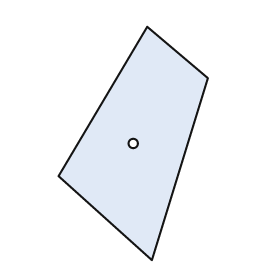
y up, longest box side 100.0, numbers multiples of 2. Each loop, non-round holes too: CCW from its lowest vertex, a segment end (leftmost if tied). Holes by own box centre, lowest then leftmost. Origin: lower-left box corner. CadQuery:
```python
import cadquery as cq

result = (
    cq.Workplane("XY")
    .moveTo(40.0, 0.0)
    .lineTo(64.0, 78.0)
    .lineTo(38.0, 100.0)
    .lineTo(0.0, 36.0)
    .close()
    .moveTo(32.0, 50.0)
    .circle(2.0)
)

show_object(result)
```